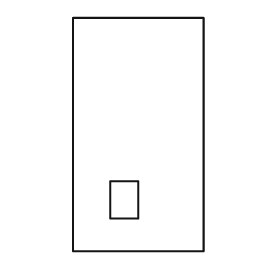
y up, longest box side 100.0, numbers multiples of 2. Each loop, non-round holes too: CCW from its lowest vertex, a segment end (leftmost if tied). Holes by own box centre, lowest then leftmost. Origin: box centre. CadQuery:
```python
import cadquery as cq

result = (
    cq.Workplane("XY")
    .moveTo(-28.0, -50.0)
    .lineTo(28.0, -50.0)
    .lineTo(28.0, 50.0)
    .lineTo(-28.0, 50.0)
    .close()
    .moveTo(-12.0, -36.0)
    .lineTo(0.0, -36.0)
    .lineTo(0.0, -20.0)
    .lineTo(-12.0, -20.0)
    .close()
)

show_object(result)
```